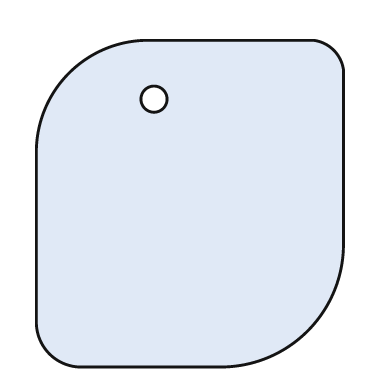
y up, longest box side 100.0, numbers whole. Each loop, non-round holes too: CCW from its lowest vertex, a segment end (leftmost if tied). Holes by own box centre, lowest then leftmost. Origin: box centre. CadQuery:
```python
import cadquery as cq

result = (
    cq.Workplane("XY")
    .moveTo(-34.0, -50.0)
    .lineTo(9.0, -50.0)
    .threePointArc((36.0, -39.0), (47.0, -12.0))
    .lineTo(47.0, 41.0)
    .threePointArc((44.0, 47.0), (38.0, 50.0))
    .lineTo(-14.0, 50.0)
    .threePointArc((-37.0, 40.0), (-47.0, 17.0))
    .lineTo(-47.0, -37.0)
    .threePointArc((-43.0, -46.0), (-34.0, -50.0))
    .close()
    .moveTo(-11.0, 32.0)
    .circle(4.0)
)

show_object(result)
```